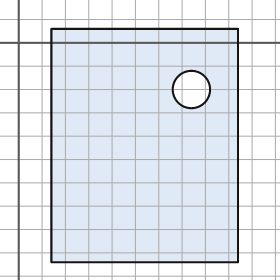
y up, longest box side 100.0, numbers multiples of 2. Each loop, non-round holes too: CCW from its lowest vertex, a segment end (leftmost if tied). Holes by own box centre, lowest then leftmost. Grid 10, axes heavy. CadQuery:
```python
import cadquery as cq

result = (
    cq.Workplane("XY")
    .moveTo(14.0, -94.0)
    .lineTo(94.0, -94.0)
    .lineTo(94.0, 6.0)
    .lineTo(14.0, 6.0)
    .close()
    .moveTo(74.0, -20.0)
    .circle(8.0)
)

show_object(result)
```